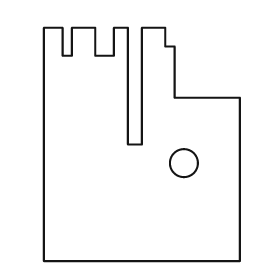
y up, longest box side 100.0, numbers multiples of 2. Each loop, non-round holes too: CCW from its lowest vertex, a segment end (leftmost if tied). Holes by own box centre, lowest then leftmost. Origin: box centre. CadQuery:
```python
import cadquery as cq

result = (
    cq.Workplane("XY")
    .moveTo(-42.0, -50.0)
    .lineTo(42.0, -50.0)
    .lineTo(42.0, 20.0)
    .lineTo(14.0, 20.0)
    .lineTo(14.0, 42.0)
    .lineTo(10.0, 42.0)
    .lineTo(10.0, 50.0)
    .lineTo(0.0, 50.0)
    .lineTo(0.0, 0.0)
    .lineTo(-6.0, 0.0)
    .lineTo(-6.0, 50.0)
    .lineTo(-12.0, 50.0)
    .lineTo(-12.0, 38.0)
    .lineTo(-20.0, 38.0)
    .lineTo(-20.0, 50.0)
    .lineTo(-30.0, 50.0)
    .lineTo(-30.0, 38.0)
    .lineTo(-34.0, 38.0)
    .lineTo(-34.0, 50.0)
    .lineTo(-42.0, 50.0)
    .close()
    .moveTo(18.0, -8.0)
    .circle(6.0)
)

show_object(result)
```